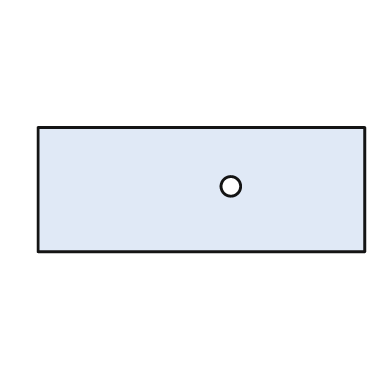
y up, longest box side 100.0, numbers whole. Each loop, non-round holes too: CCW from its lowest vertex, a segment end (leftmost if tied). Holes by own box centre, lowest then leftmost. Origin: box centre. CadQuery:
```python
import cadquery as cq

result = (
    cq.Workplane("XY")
    .moveTo(-50.0, -19.0)
    .lineTo(50.0, -19.0)
    .lineTo(50.0, 19.0)
    .lineTo(-50.0, 19.0)
    .close()
    .moveTo(9.0, 1.0)
    .circle(3.0)
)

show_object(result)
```